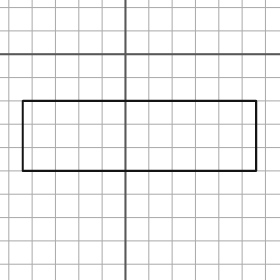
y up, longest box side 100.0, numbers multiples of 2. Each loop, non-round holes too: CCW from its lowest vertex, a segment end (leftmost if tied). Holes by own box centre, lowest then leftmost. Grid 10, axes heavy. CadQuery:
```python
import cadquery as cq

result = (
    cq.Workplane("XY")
    .moveTo(-44.0, -50.0)
    .lineTo(56.0, -50.0)
    .lineTo(56.0, -20.0)
    .lineTo(-44.0, -20.0)
    .close()
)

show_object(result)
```